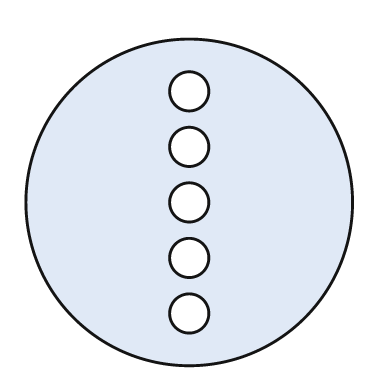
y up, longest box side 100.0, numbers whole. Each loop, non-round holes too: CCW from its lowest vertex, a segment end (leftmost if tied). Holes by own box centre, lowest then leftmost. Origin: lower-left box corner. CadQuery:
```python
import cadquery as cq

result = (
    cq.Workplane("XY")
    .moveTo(50.0, 50.0)
    .circle(50.0)
    .moveTo(50.0, 16.0)
    .circle(6.0)
    .moveTo(50.0, 33.0)
    .circle(6.0)
    .moveTo(50.0, 50.0)
    .circle(6.0)
    .moveTo(50.0, 67.0)
    .circle(6.0)
    .moveTo(50.0, 84.0)
    .circle(6.0)
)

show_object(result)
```